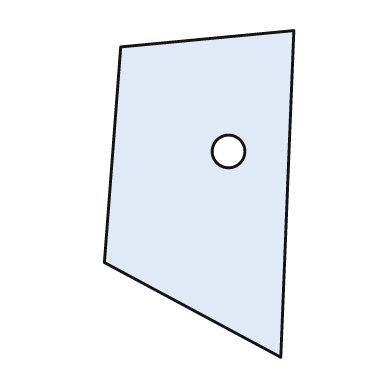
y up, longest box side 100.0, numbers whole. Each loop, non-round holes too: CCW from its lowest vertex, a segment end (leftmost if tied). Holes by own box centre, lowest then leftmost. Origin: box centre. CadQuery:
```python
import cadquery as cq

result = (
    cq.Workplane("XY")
    .moveTo(25.0, -50.0)
    .lineTo(29.0, 50.0)
    .lineTo(-24.0, 45.0)
    .lineTo(-29.0, -21.0)
    .close()
    .moveTo(9.0, 13.0)
    .circle(5.0)
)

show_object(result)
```